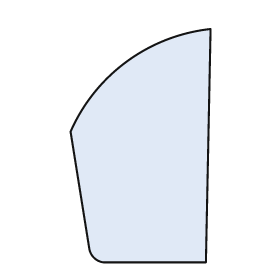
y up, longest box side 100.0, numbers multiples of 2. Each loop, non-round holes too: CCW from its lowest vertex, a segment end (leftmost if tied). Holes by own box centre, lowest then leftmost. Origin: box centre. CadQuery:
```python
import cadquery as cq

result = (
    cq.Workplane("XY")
    .moveTo(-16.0, -50.0)
    .lineTo(28.0, -50.0)
    .lineTo(30.0, 50.0)
    .threePointArc((-6.0, 36.0), (-30.0, 6.0))
    .lineTo(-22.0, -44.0)
    .threePointArc((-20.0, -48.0), (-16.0, -50.0))
    .close()
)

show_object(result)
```